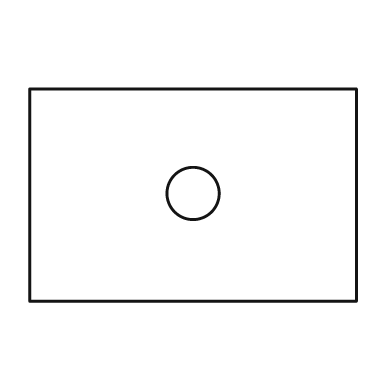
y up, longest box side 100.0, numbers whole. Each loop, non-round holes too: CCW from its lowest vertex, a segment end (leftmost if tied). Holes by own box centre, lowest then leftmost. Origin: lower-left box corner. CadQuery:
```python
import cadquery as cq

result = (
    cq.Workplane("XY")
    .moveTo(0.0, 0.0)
    .lineTo(100.0, 0.0)
    .lineTo(100.0, 65.0)
    .lineTo(0.0, 65.0)
    .close()
    .moveTo(50.0, 33.0)
    .circle(8.0)
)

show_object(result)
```